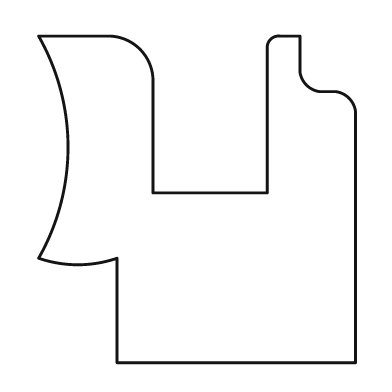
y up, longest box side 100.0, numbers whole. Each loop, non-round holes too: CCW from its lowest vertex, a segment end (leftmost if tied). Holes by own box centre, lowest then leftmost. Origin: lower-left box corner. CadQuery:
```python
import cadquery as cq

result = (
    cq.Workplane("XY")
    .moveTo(24.0, 0.0)
    .lineTo(97.0, 0.0)
    .lineTo(97.0, 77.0)
    .threePointArc((95.0, 81.0), (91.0, 83.0))
    .lineTo(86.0, 83.0)
    .threePointArc((82.0, 85.0), (80.0, 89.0))
    .lineTo(80.0, 100.0)
    .lineTo(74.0, 100.0)
    .threePointArc((71.0, 99.0), (70.0, 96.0))
    .lineTo(70.0, 52.0)
    .lineTo(35.0, 52.0)
    .lineTo(35.0, 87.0)
    .threePointArc((31.0, 96.0), (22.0, 100.0))
    .lineTo(0.0, 100.0)
    .threePointArc((9.0, 66.0), (0.0, 32.0))
    .threePointArc((12.0, 30.0), (24.0, 32.0))
    .close()
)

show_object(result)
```